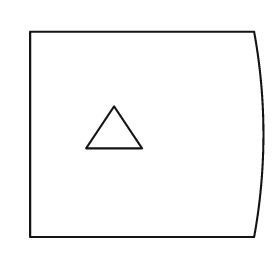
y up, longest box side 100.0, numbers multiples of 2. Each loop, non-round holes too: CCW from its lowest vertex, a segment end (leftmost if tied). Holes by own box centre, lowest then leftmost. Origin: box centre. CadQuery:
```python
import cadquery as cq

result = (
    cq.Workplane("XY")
    .moveTo(-50.0, -44.0)
    .lineTo(46.0, -44.0)
    .threePointArc((50.0, 0.0), (46.0, 44.0))
    .lineTo(-50.0, 44.0)
    .close()
    .moveTo(-26.0, -6.0)
    .lineTo(-2.0, -6.0)
    .lineTo(-14.0, 12.0)
    .close()
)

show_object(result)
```